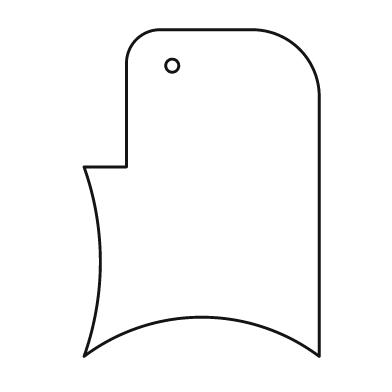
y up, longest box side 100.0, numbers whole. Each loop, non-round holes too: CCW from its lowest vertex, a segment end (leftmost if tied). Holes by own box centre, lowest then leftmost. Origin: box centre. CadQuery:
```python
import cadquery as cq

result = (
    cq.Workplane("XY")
    .moveTo(-36.0, -50.0)
    .threePointArc((0.0, -38.0), (36.0, -50.0))
    .lineTo(36.0, 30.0)
    .threePointArc((30.0, 44.0), (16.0, 50.0))
    .lineTo(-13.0, 50.0)
    .threePointArc((-20.0, 47.0), (-23.0, 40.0))
    .lineTo(-23.0, 8.0)
    .lineTo(-36.0, 8.0)
    .threePointArc((-31.0, -21.0), (-36.0, -50.0))
    .close()
    .moveTo(-9.0, 39.0)
    .circle(2.0)
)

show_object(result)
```